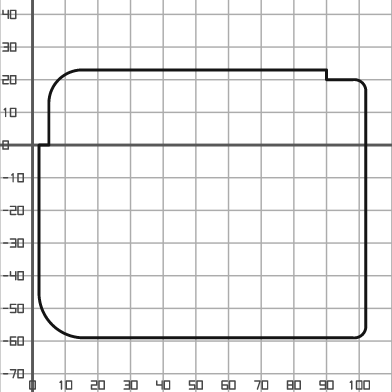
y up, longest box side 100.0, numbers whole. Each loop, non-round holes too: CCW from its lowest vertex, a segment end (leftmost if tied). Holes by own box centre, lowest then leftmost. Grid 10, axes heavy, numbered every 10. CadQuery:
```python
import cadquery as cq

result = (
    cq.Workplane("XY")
    .moveTo(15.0, -59.0)
    .lineTo(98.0, -59.0)
    .threePointArc((101.0, -58.0), (102.0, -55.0))
    .lineTo(102.0, 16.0)
    .threePointArc((101.0, 19.0), (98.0, 20.0))
    .lineTo(90.0, 20.0)
    .lineTo(90.0, 23.0)
    .lineTo(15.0, 23.0)
    .threePointArc((8.0, 20.0), (5.0, 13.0))
    .lineTo(5.0, 0.0)
    .lineTo(2.0, 0.0)
    .lineTo(2.0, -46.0)
    .threePointArc((6.0, -55.0), (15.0, -59.0))
    .close()
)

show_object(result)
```